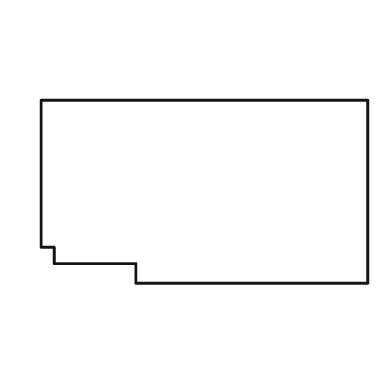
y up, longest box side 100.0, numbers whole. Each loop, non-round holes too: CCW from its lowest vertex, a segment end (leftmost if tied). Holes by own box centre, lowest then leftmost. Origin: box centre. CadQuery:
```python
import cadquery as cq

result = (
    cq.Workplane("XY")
    .moveTo(-21.0, -28.0)
    .lineTo(50.0, -28.0)
    .lineTo(50.0, 28.0)
    .lineTo(-50.0, 28.0)
    .lineTo(-50.0, -17.0)
    .lineTo(-46.0, -17.0)
    .lineTo(-46.0, -22.0)
    .lineTo(-21.0, -22.0)
    .close()
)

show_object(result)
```